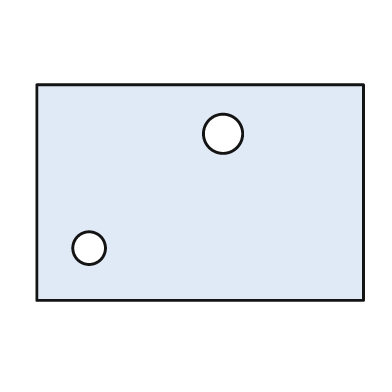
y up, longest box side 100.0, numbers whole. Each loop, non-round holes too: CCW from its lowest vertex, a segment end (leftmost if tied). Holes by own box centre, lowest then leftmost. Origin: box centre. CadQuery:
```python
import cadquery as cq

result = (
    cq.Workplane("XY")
    .moveTo(-50.0, -33.0)
    .lineTo(50.0, -33.0)
    .lineTo(50.0, 33.0)
    .lineTo(-50.0, 33.0)
    .close()
    .moveTo(-34.0, -17.0)
    .circle(5.0)
    .moveTo(7.0, 18.0)
    .circle(6.0)
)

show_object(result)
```